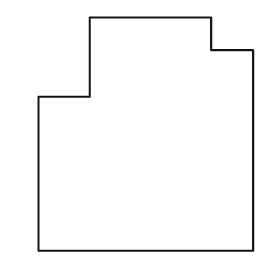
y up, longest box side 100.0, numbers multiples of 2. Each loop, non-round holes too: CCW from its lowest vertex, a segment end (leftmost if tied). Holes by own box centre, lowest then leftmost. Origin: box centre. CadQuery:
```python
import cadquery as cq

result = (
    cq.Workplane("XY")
    .moveTo(-46.0, -50.0)
    .lineTo(46.0, -50.0)
    .lineTo(46.0, 36.0)
    .lineTo(28.0, 36.0)
    .lineTo(28.0, 50.0)
    .lineTo(-24.0, 50.0)
    .lineTo(-24.0, 16.0)
    .lineTo(-46.0, 16.0)
    .close()
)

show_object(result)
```